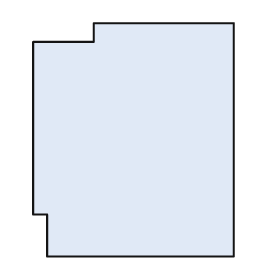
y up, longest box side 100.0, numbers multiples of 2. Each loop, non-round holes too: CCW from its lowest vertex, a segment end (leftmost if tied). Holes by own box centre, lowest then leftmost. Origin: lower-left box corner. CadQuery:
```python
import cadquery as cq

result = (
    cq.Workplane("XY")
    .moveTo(6.0, 0.0)
    .lineTo(86.0, 0.0)
    .lineTo(86.0, 100.0)
    .lineTo(26.0, 100.0)
    .lineTo(26.0, 92.0)
    .lineTo(0.0, 92.0)
    .lineTo(0.0, 18.0)
    .lineTo(6.0, 18.0)
    .close()
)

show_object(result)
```